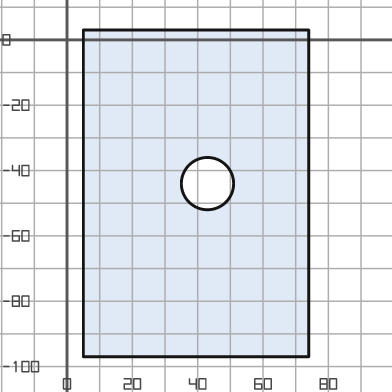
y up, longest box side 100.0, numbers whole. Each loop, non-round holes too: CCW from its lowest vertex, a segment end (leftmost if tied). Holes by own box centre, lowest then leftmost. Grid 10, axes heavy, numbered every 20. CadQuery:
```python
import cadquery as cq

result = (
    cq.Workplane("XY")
    .moveTo(5.0, -97.0)
    .lineTo(74.0, -97.0)
    .lineTo(74.0, 3.0)
    .lineTo(5.0, 3.0)
    .close()
    .moveTo(43.0, -44.0)
    .circle(8.0)
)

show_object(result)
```